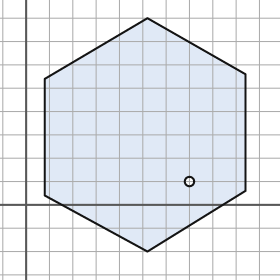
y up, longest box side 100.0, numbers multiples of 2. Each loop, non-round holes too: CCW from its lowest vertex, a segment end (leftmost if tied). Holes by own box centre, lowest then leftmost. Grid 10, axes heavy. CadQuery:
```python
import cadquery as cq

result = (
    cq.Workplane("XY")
    .moveTo(52.0, -20.0)
    .lineTo(94.0, 6.0)
    .lineTo(94.0, 56.0)
    .lineTo(52.0, 80.0)
    .lineTo(8.0, 54.0)
    .lineTo(8.0, 4.0)
    .close()
    .moveTo(70.0, 10.0)
    .circle(2.0)
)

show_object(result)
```